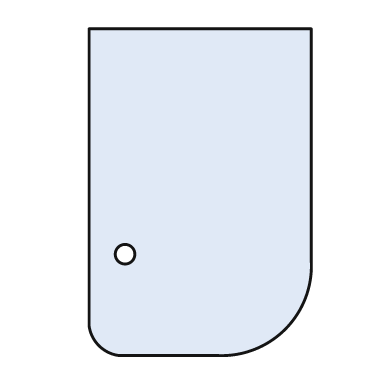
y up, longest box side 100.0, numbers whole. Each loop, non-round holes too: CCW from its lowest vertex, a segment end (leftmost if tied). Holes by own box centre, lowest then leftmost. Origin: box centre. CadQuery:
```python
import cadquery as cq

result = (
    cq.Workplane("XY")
    .moveTo(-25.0, -50.0)
    .lineTo(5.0, -50.0)
    .threePointArc((26.0, -42.0), (34.0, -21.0))
    .lineTo(34.0, 50.0)
    .lineTo(-34.0, 50.0)
    .lineTo(-34.0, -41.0)
    .threePointArc((-31.0, -47.0), (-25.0, -50.0))
    .close()
    .moveTo(-23.0, -19.0)
    .circle(3.0)
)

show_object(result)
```